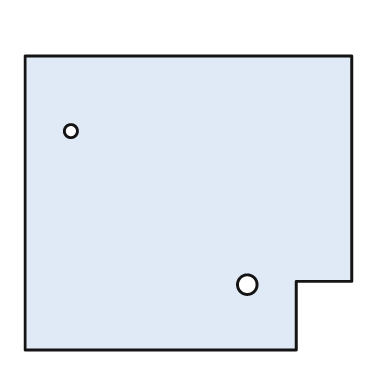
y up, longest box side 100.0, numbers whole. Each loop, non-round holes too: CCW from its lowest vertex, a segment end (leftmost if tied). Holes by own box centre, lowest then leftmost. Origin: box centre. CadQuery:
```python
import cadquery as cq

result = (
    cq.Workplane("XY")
    .moveTo(-50.0, -45.0)
    .lineTo(33.0, -45.0)
    .lineTo(33.0, -24.0)
    .lineTo(50.0, -24.0)
    .lineTo(50.0, 45.0)
    .lineTo(-50.0, 45.0)
    .close()
    .moveTo(18.0, -25.0)
    .circle(3.0)
    .moveTo(-36.0, 22.0)
    .circle(2.0)
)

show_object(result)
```